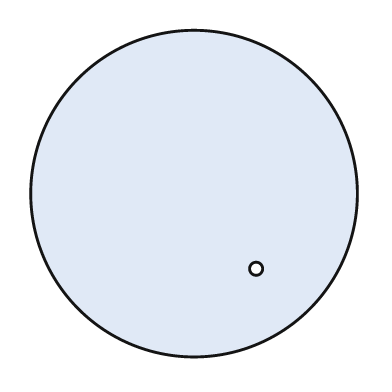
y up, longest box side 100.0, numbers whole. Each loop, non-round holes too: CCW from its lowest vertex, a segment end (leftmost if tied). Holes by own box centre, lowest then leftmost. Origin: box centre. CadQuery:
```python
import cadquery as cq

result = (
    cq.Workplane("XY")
    .moveTo(0.0, 0.0)
    .circle(50.0)
    .moveTo(19.0, -23.0)
    .circle(2.0)
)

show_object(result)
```